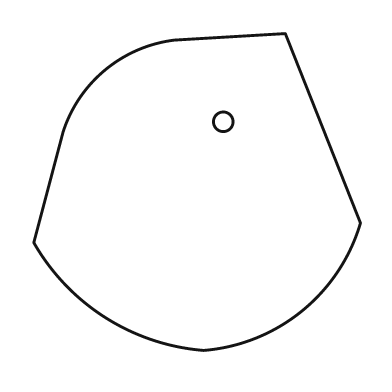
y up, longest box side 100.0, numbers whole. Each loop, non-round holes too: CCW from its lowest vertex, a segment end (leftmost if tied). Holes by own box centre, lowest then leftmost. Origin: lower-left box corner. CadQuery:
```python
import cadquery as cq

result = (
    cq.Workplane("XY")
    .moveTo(52.0, 0.0)
    .threePointArc((82.0, 12.0), (100.0, 39.0))
    .lineTo(77.0, 97.0)
    .lineTo(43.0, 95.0)
    .threePointArc((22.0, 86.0), (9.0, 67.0))
    .lineTo(0.0, 33.0)
    .threePointArc((22.0, 10.0), (52.0, 0.0))
    .close()
    .moveTo(58.0, 70.0)
    .circle(3.0)
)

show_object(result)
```